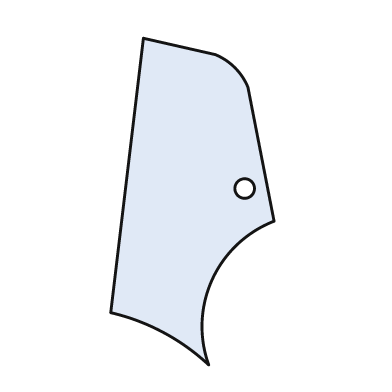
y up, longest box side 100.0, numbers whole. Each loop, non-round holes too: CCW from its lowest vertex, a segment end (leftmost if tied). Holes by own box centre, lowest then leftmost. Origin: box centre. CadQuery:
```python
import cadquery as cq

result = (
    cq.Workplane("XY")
    .moveTo(5.0, -50.0)
    .threePointArc((6.0, -24.0), (25.0, -6.0))
    .lineTo(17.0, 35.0)
    .threePointArc((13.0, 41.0), (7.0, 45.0))
    .lineTo(-15.0, 50.0)
    .lineTo(-25.0, -34.0)
    .threePointArc((-9.0, -40.0), (5.0, -50.0))
    .close()
    .moveTo(16.0, 4.0)
    .circle(3.0)
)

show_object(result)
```